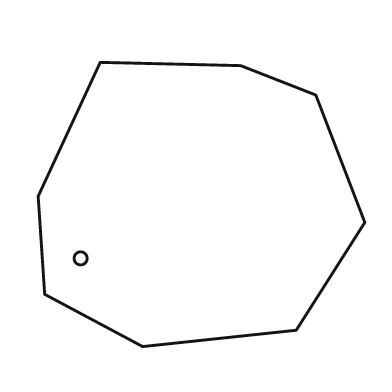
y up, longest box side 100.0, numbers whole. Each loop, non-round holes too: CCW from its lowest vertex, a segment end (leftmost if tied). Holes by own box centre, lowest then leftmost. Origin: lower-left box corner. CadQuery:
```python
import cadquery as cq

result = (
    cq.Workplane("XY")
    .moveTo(32.0, 0.0)
    .lineTo(79.0, 5.0)
    .lineTo(100.0, 38.0)
    .lineTo(85.0, 77.0)
    .lineTo(62.0, 86.0)
    .lineTo(19.0, 87.0)
    .lineTo(0.0, 46.0)
    .lineTo(2.0, 16.0)
    .close()
    .moveTo(13.0, 27.0)
    .circle(2.0)
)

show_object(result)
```